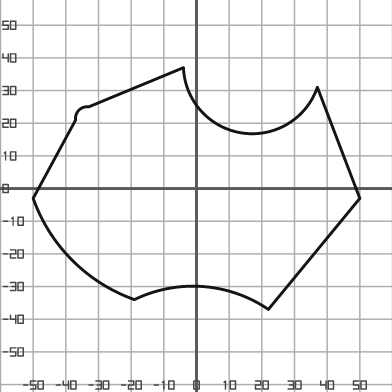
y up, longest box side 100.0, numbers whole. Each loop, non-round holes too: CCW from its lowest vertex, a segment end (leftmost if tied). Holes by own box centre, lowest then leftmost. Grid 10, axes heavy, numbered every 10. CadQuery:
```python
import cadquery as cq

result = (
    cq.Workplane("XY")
    .moveTo(22.0, -37.0)
    .lineTo(50.0, -3.0)
    .lineTo(37.0, 31.0)
    .threePointArc((14.0, 17.0), (-4.0, 37.0))
    .lineTo(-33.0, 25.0)
    .threePointArc((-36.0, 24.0), (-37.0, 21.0))
    .lineTo(-50.0, -3.0)
    .threePointArc((-38.0, -22.0), (-19.0, -34.0))
    .threePointArc((2.0, -30.0), (22.0, -37.0))
    .close()
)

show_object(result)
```